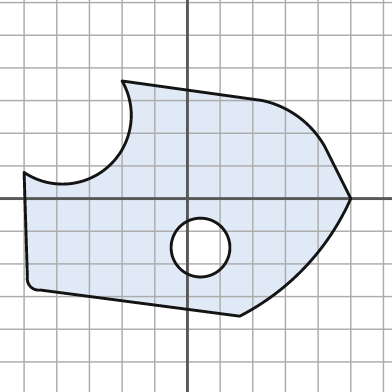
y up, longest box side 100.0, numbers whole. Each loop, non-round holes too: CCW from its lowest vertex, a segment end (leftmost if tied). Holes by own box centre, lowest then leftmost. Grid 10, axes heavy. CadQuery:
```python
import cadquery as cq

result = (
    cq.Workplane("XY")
    .moveTo(16.0, -36.0)
    .threePointArc((36.0, -21.0), (50.0, 0.0))
    .lineTo(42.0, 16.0)
    .threePointArc((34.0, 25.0), (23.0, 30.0))
    .lineTo(-20.0, 36.0)
    .threePointArc((-24.0, 10.0), (-50.0, 8.0))
    .lineTo(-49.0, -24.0)
    .threePointArc((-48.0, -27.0), (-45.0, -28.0))
    .close()
    .moveTo(4.0, -15.0)
    .circle(9.0)
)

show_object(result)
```